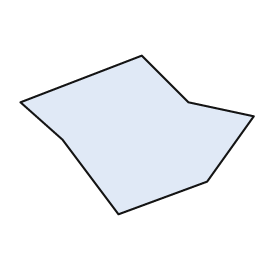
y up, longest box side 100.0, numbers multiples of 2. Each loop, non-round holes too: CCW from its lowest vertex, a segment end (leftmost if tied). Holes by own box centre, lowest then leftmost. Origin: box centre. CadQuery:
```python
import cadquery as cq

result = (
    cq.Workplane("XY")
    .moveTo(-8.0, -34.0)
    .lineTo(30.0, -20.0)
    .lineTo(50.0, 8.0)
    .lineTo(22.0, 14.0)
    .lineTo(2.0, 34.0)
    .lineTo(-50.0, 14.0)
    .lineTo(-32.0, -2.0)
    .close()
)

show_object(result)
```